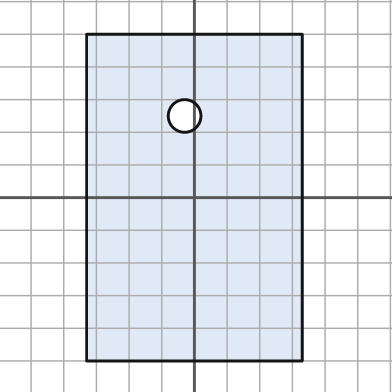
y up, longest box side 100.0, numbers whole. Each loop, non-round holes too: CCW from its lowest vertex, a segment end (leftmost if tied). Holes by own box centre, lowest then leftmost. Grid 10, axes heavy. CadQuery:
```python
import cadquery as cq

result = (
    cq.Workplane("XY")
    .moveTo(-33.0, -50.0)
    .lineTo(33.0, -50.0)
    .lineTo(33.0, 50.0)
    .lineTo(-33.0, 50.0)
    .close()
    .moveTo(-3.0, 25.0)
    .circle(5.0)
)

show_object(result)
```